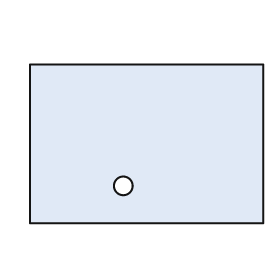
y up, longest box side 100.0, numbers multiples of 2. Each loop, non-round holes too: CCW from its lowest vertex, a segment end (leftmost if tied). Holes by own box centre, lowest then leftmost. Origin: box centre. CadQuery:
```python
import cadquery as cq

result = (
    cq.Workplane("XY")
    .moveTo(-50.0, -34.0)
    .lineTo(50.0, -34.0)
    .lineTo(50.0, 34.0)
    .lineTo(-50.0, 34.0)
    .close()
    .moveTo(-10.0, -18.0)
    .circle(4.0)
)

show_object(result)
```